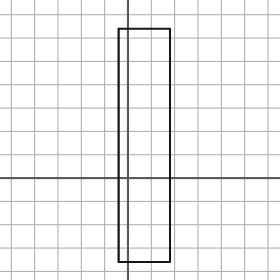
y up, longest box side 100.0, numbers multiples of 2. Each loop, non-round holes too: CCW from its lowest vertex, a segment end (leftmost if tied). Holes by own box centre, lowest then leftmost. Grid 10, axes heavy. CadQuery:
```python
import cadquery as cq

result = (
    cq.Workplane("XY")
    .moveTo(-4.0, -36.0)
    .lineTo(18.0, -36.0)
    .lineTo(18.0, 64.0)
    .lineTo(-4.0, 64.0)
    .close()
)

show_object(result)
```